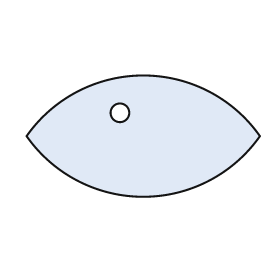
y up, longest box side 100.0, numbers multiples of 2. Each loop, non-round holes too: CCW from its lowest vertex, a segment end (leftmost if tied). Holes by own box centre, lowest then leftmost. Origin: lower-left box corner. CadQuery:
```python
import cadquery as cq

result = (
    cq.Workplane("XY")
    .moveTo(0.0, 26.0)
    .threePointArc((50.0, 0.0), (100.0, 26.0))
    .threePointArc((50.0, 52.0), (0.0, 26.0))
    .close()
    .moveTo(40.0, 36.0)
    .circle(4.0)
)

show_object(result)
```